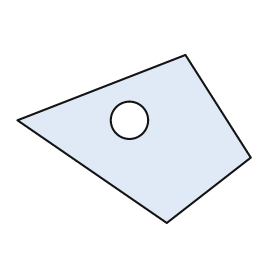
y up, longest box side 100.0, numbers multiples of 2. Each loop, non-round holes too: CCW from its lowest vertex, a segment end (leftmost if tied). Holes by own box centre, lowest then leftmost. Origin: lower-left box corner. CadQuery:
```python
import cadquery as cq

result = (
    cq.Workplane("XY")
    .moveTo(64.0, 0.0)
    .lineTo(100.0, 28.0)
    .lineTo(72.0, 72.0)
    .lineTo(0.0, 44.0)
    .close()
    .moveTo(48.0, 44.0)
    .circle(8.0)
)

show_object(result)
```